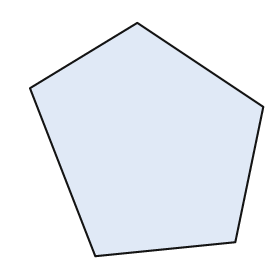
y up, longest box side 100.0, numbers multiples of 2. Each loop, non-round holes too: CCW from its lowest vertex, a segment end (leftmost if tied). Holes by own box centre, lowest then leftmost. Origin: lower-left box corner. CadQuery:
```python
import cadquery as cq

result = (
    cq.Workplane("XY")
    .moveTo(28.0, 0.0)
    .lineTo(88.0, 6.0)
    .lineTo(100.0, 64.0)
    .lineTo(46.0, 100.0)
    .lineTo(0.0, 72.0)
    .close()
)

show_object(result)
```